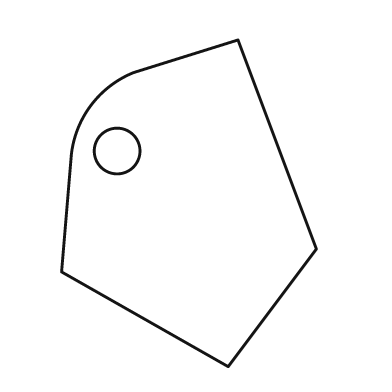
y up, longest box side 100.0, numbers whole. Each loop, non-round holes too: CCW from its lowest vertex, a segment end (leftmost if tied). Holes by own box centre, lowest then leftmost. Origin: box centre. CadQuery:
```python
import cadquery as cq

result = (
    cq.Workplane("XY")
    .moveTo(12.0, -50.0)
    .lineTo(39.0, -14.0)
    .lineTo(15.0, 50.0)
    .lineTo(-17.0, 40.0)
    .threePointArc((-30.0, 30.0), (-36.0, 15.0))
    .lineTo(-39.0, -21.0)
    .close()
    .moveTo(-22.0, 16.0)
    .circle(7.0)
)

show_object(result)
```